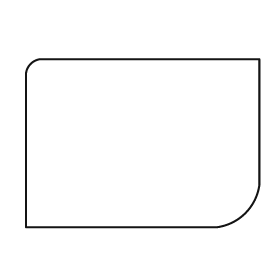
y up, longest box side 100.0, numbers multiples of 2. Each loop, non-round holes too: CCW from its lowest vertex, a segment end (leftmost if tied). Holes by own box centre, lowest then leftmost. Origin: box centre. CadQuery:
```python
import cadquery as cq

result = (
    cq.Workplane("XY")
    .moveTo(-50.0, -36.0)
    .lineTo(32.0, -36.0)
    .threePointArc((44.0, -30.0), (50.0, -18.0))
    .lineTo(50.0, 36.0)
    .lineTo(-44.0, 36.0)
    .threePointArc((-48.0, 34.0), (-50.0, 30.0))
    .close()
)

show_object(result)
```